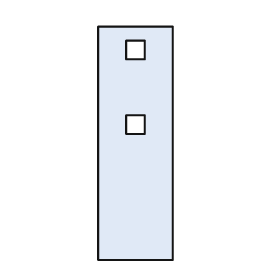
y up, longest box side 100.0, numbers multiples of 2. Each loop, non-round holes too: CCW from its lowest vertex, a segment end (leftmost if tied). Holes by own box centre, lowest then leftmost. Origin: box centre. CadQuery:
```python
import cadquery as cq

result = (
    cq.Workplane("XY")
    .moveTo(-16.0, -50.0)
    .lineTo(16.0, -50.0)
    .lineTo(16.0, 50.0)
    .lineTo(-16.0, 50.0)
    .close()
    .moveTo(-4.0, 4.0)
    .lineTo(4.0, 4.0)
    .lineTo(4.0, 12.0)
    .lineTo(-4.0, 12.0)
    .close()
    .moveTo(-4.0, 36.0)
    .lineTo(4.0, 36.0)
    .lineTo(4.0, 44.0)
    .lineTo(-4.0, 44.0)
    .close()
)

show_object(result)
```